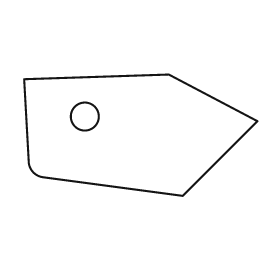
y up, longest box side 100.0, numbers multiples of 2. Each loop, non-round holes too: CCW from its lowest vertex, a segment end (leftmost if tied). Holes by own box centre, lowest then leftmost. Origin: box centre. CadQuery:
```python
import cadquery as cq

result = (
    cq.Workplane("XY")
    .moveTo(18.0, -26.0)
    .lineTo(50.0, 6.0)
    .lineTo(12.0, 26.0)
    .lineTo(-50.0, 24.0)
    .lineTo(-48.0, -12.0)
    .threePointArc((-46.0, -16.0), (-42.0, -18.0))
    .close()
    .moveTo(-24.0, 8.0)
    .circle(6.0)
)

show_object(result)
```